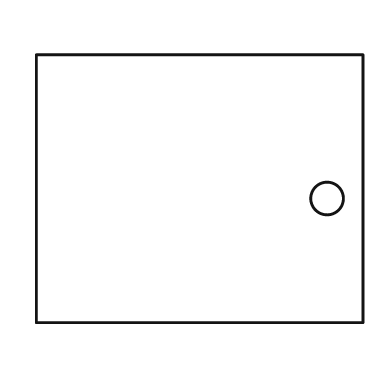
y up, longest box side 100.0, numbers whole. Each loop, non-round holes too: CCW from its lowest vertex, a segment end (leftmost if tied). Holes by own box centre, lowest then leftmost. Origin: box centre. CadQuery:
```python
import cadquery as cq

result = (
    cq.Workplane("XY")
    .moveTo(-50.0, -41.0)
    .lineTo(50.0, -41.0)
    .lineTo(50.0, 41.0)
    .lineTo(-50.0, 41.0)
    .close()
    .moveTo(39.0, -3.0)
    .circle(5.0)
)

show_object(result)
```